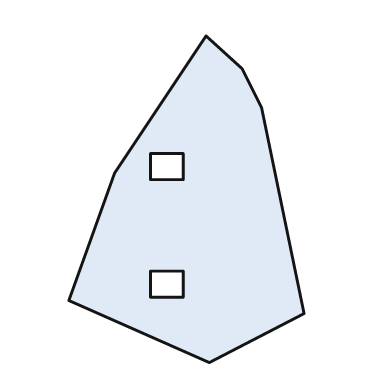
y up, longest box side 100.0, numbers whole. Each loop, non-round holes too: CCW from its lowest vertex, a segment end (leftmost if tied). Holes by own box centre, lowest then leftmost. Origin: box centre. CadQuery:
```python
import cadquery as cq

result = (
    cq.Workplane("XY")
    .moveTo(7.0, -50.0)
    .lineTo(36.0, -35.0)
    .lineTo(23.0, 28.0)
    .lineTo(17.0, 40.0)
    .lineTo(6.0, 50.0)
    .lineTo(-22.0, 8.0)
    .lineTo(-36.0, -31.0)
    .close()
    .moveTo(-11.0, -30.0)
    .lineTo(-1.0, -30.0)
    .lineTo(-1.0, -22.0)
    .lineTo(-11.0, -22.0)
    .close()
    .moveTo(-11.0, 6.0)
    .lineTo(-1.0, 6.0)
    .lineTo(-1.0, 14.0)
    .lineTo(-11.0, 14.0)
    .close()
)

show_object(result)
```